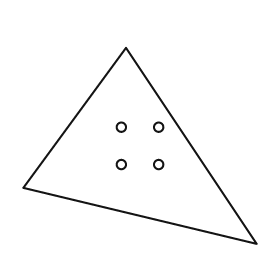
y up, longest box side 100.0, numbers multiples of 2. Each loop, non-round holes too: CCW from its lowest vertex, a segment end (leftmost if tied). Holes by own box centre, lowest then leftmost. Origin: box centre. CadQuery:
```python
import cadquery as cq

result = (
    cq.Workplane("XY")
    .moveTo(50.0, -42.0)
    .lineTo(-6.0, 42.0)
    .lineTo(-50.0, -18.0)
    .close()
    .moveTo(-8.0, -8.0)
    .circle(2.0)
    .moveTo(8.0, -8.0)
    .circle(2.0)
    .moveTo(-8.0, 8.0)
    .circle(2.0)
    .moveTo(8.0, 8.0)
    .circle(2.0)
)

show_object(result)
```